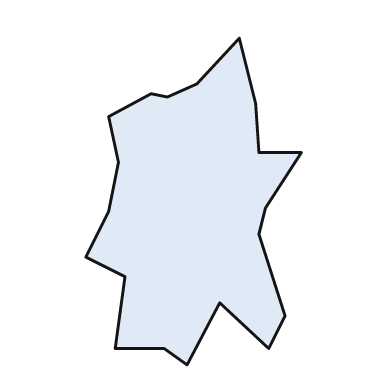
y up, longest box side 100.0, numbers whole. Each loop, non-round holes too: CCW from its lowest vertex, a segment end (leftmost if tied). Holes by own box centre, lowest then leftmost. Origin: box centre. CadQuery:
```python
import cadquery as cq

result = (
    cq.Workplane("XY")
    .moveTo(-2.0, -50.0)
    .lineTo(8.0, -31.0)
    .lineTo(23.0, -45.0)
    .lineTo(28.0, -35.0)
    .lineTo(20.0, -10.0)
    .lineTo(22.0, -2.0)
    .lineTo(33.0, 15.0)
    .lineTo(20.0, 15.0)
    .lineTo(19.0, 30.0)
    .lineTo(14.0, 50.0)
    .lineTo(1.0, 36.0)
    .lineTo(-8.0, 32.0)
    .lineTo(-13.0, 33.0)
    .lineTo(-26.0, 26.0)
    .lineTo(-23.0, 12.0)
    .lineTo(-26.0, -3.0)
    .lineTo(-33.0, -17.0)
    .lineTo(-21.0, -23.0)
    .lineTo(-24.0, -45.0)
    .lineTo(-9.0, -45.0)
    .close()
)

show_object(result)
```